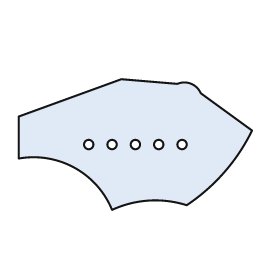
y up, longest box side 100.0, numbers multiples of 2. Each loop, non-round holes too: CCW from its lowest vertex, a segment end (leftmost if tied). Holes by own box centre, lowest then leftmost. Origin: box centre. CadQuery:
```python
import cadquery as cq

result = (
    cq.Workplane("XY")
    .moveTo(-10.0, -28.0)
    .threePointArc((6.0, -24.0), (22.0, -26.0))
    .threePointArc((38.0, -12.0), (50.0, 6.0))
    .lineTo(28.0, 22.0)
    .threePointArc((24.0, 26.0), (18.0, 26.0))
    .lineTo(-6.0, 28.0)
    .lineTo(-50.0, 12.0)
    .lineTo(-50.0, -6.0)
    .threePointArc((-26.0, -10.0), (-10.0, -28.0))
    .close()
    .moveTo(-20.0, 0.0)
    .circle(2.0)
    .moveTo(-10.0, 0.0)
    .circle(2.0)
    .moveTo(0.0, 0.0)
    .circle(2.0)
    .moveTo(10.0, 0.0)
    .circle(2.0)
    .moveTo(20.0, 0.0)
    .circle(2.0)
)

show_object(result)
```